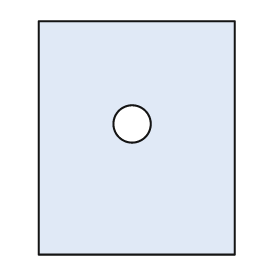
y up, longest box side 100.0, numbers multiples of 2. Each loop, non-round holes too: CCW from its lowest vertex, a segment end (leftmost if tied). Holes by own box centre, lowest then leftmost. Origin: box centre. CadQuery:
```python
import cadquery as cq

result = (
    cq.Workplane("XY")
    .moveTo(-42.0, -50.0)
    .lineTo(42.0, -50.0)
    .lineTo(42.0, 50.0)
    .lineTo(-42.0, 50.0)
    .close()
    .moveTo(-2.0, 6.0)
    .circle(8.0)
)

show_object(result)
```